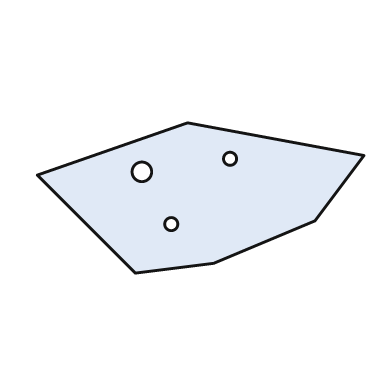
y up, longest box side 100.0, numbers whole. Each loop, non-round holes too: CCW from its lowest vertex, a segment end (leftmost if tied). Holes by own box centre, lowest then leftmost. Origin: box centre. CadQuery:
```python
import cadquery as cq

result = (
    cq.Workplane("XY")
    .moveTo(-20.0, -23.0)
    .lineTo(4.0, -20.0)
    .lineTo(35.0, -7.0)
    .lineTo(50.0, 13.0)
    .lineTo(-4.0, 23.0)
    .lineTo(-50.0, 7.0)
    .close()
    .moveTo(-9.0, -8.0)
    .circle(2.0)
    .moveTo(-18.0, 8.0)
    .circle(3.0)
    .moveTo(9.0, 12.0)
    .circle(2.0)
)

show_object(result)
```